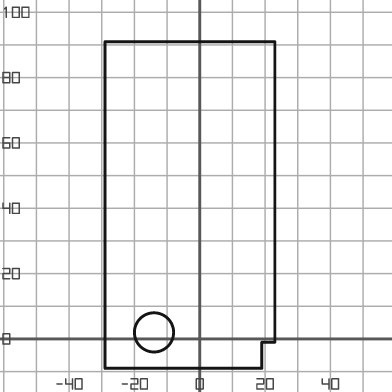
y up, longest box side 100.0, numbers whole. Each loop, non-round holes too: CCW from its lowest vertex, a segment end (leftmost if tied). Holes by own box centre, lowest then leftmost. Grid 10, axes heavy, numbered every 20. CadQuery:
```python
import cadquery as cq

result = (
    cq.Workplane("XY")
    .moveTo(-29.0, -9.0)
    .lineTo(19.0, -9.0)
    .lineTo(19.0, -1.0)
    .lineTo(23.0, -1.0)
    .lineTo(23.0, 91.0)
    .lineTo(-29.0, 91.0)
    .close()
    .moveTo(-14.0, 2.0)
    .circle(6.0)
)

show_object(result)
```